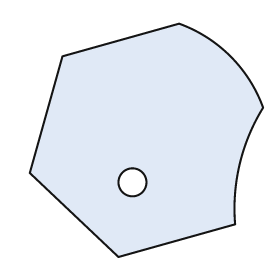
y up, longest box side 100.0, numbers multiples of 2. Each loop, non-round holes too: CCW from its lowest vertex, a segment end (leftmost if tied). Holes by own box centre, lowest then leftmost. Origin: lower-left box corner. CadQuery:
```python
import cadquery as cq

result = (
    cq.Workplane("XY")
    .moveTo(38.0, 0.0)
    .lineTo(88.0, 14.0)
    .threePointArc((90.0, 40.0), (100.0, 64.0))
    .threePointArc((86.0, 86.0), (64.0, 100.0))
    .lineTo(14.0, 86.0)
    .lineTo(0.0, 36.0)
    .close()
    .moveTo(44.0, 32.0)
    .circle(6.0)
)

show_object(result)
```